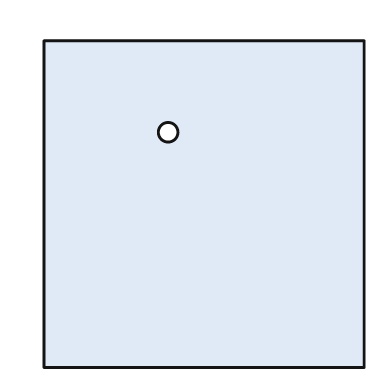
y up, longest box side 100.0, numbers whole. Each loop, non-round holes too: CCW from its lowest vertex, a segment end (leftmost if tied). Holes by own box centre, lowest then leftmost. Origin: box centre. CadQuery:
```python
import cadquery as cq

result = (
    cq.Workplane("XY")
    .moveTo(-49.0, -50.0)
    .lineTo(49.0, -50.0)
    .lineTo(49.0, 50.0)
    .lineTo(-49.0, 50.0)
    .close()
    .moveTo(-11.0, 22.0)
    .circle(3.0)
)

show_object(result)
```